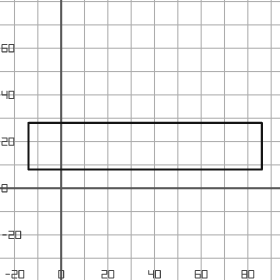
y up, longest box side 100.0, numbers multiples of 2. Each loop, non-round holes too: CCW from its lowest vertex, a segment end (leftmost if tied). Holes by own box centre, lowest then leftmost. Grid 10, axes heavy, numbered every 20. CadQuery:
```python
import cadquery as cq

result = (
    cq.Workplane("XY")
    .moveTo(-14.0, 8.0)
    .lineTo(86.0, 8.0)
    .lineTo(86.0, 28.0)
    .lineTo(-14.0, 28.0)
    .close()
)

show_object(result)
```